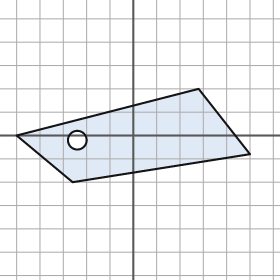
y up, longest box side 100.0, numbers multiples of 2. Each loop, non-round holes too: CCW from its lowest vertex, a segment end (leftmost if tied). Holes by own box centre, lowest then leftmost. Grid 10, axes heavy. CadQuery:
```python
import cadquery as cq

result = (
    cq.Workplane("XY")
    .moveTo(-26.0, -20.0)
    .lineTo(50.0, -8.0)
    .lineTo(28.0, 20.0)
    .lineTo(-50.0, 0.0)
    .close()
    .moveTo(-24.0, -2.0)
    .circle(4.0)
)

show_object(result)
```